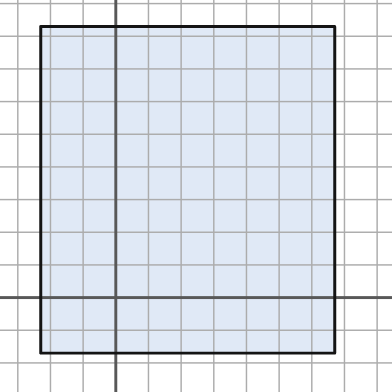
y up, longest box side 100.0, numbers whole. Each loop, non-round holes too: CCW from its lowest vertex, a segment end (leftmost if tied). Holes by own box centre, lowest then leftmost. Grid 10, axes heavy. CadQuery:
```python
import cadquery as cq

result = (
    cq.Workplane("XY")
    .moveTo(-23.0, -17.0)
    .lineTo(67.0, -17.0)
    .lineTo(67.0, 83.0)
    .lineTo(-23.0, 83.0)
    .close()
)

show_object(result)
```